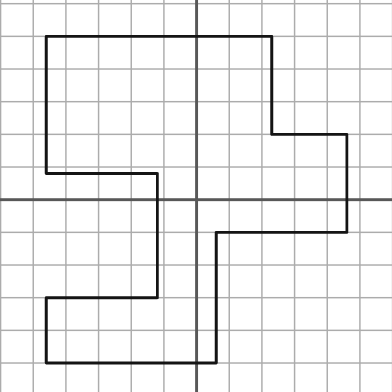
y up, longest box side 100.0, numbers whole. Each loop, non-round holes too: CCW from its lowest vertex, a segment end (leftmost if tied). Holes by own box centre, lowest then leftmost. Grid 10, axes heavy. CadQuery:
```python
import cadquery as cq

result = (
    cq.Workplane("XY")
    .moveTo(-46.0, -50.0)
    .lineTo(6.0, -50.0)
    .lineTo(6.0, -10.0)
    .lineTo(46.0, -10.0)
    .lineTo(46.0, 20.0)
    .lineTo(23.0, 20.0)
    .lineTo(23.0, 50.0)
    .lineTo(-46.0, 50.0)
    .lineTo(-46.0, 8.0)
    .lineTo(-12.0, 8.0)
    .lineTo(-12.0, -30.0)
    .lineTo(-46.0, -30.0)
    .close()
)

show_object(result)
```